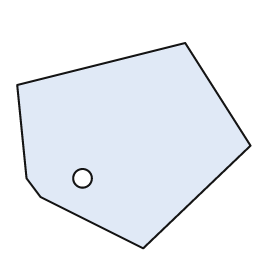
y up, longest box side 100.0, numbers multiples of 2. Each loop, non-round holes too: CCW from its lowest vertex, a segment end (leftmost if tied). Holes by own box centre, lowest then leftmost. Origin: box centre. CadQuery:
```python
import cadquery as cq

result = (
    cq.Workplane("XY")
    .moveTo(4.0, -44.0)
    .lineTo(50.0, 0.0)
    .lineTo(22.0, 44.0)
    .lineTo(-50.0, 26.0)
    .lineTo(-46.0, -14.0)
    .lineTo(-40.0, -22.0)
    .close()
    .moveTo(-22.0, -14.0)
    .circle(4.0)
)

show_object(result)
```